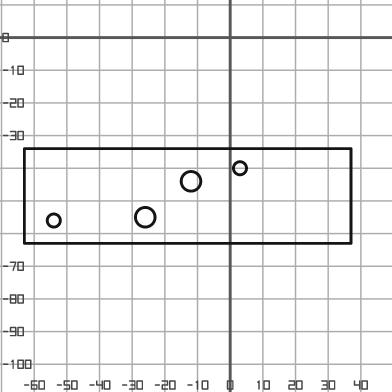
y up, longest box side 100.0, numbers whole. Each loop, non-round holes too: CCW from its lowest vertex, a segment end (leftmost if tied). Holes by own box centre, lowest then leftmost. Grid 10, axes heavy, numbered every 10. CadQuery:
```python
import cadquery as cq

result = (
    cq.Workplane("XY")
    .moveTo(-63.0, -63.0)
    .lineTo(37.0, -63.0)
    .lineTo(37.0, -34.0)
    .lineTo(-63.0, -34.0)
    .close()
    .moveTo(-54.0, -56.0)
    .circle(2.0)
    .moveTo(-26.0, -55.0)
    .circle(3.0)
    .moveTo(-12.0, -44.0)
    .circle(3.0)
    .moveTo(3.0, -40.0)
    .circle(2.0)
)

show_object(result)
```